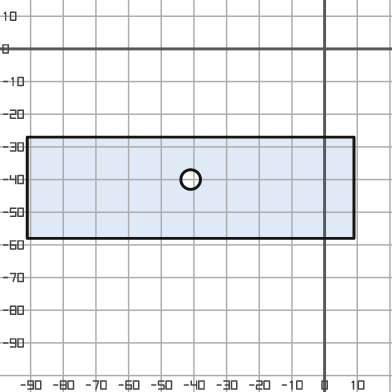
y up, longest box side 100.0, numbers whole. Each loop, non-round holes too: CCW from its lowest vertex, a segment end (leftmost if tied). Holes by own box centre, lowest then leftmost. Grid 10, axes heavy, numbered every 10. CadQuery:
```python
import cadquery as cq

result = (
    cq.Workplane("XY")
    .moveTo(-91.0, -58.0)
    .lineTo(9.0, -58.0)
    .lineTo(9.0, -27.0)
    .lineTo(-91.0, -27.0)
    .close()
    .moveTo(-41.0, -40.0)
    .circle(3.0)
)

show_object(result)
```